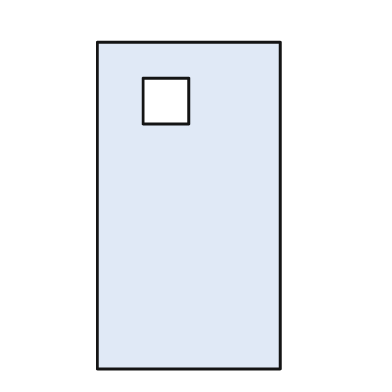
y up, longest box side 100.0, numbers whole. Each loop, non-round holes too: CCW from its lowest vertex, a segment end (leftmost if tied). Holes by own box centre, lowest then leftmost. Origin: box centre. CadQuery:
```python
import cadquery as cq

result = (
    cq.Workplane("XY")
    .moveTo(-28.0, -50.0)
    .lineTo(28.0, -50.0)
    .lineTo(28.0, 50.0)
    .lineTo(-28.0, 50.0)
    .close()
    .moveTo(-14.0, 25.0)
    .lineTo(0.0, 25.0)
    .lineTo(0.0, 39.0)
    .lineTo(-14.0, 39.0)
    .close()
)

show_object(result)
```